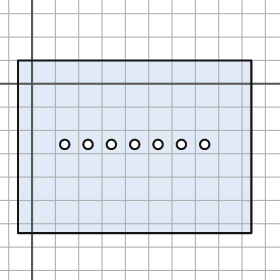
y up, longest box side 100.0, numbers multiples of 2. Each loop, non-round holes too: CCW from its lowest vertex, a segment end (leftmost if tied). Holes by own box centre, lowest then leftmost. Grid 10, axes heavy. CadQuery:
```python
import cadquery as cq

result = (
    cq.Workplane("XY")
    .moveTo(-6.0, -64.0)
    .lineTo(94.0, -64.0)
    .lineTo(94.0, 10.0)
    .lineTo(-6.0, 10.0)
    .close()
    .moveTo(14.0, -26.0)
    .circle(2.0)
    .moveTo(24.0, -26.0)
    .circle(2.0)
    .moveTo(34.0, -26.0)
    .circle(2.0)
    .moveTo(44.0, -26.0)
    .circle(2.0)
    .moveTo(54.0, -26.0)
    .circle(2.0)
    .moveTo(64.0, -26.0)
    .circle(2.0)
    .moveTo(74.0, -26.0)
    .circle(2.0)
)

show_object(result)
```